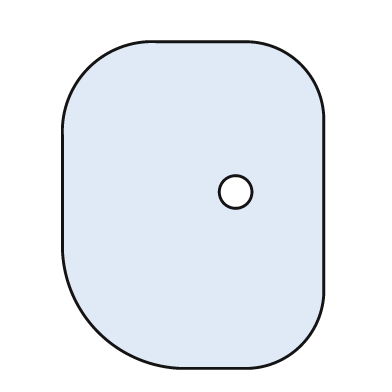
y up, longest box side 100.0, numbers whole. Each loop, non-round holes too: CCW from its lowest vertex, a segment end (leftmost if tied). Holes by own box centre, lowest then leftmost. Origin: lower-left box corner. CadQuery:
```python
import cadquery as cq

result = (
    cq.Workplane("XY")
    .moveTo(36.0, 0.0)
    .lineTo(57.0, 0.0)
    .threePointArc((73.0, 7.0), (80.0, 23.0))
    .lineTo(80.0, 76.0)
    .threePointArc((73.0, 93.0), (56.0, 100.0))
    .lineTo(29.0, 100.0)
    .threePointArc((8.0, 92.0), (0.0, 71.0))
    .lineTo(0.0, 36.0)
    .threePointArc((11.0, 11.0), (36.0, 0.0))
    .close()
    .moveTo(53.0, 54.0)
    .circle(5.0)
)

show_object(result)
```